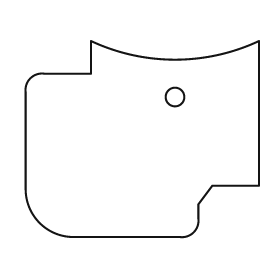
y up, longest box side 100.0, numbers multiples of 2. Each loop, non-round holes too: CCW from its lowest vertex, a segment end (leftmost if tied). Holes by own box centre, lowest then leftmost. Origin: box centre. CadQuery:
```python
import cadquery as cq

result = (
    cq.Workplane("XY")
    .moveTo(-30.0, -42.0)
    .lineTo(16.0, -42.0)
    .threePointArc((22.0, -40.0), (24.0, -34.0))
    .lineTo(24.0, -28.0)
    .lineTo(30.0, -20.0)
    .lineTo(50.0, -20.0)
    .lineTo(50.0, 42.0)
    .threePointArc((14.0, 34.0), (-22.0, 42.0))
    .lineTo(-22.0, 28.0)
    .lineTo(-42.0, 28.0)
    .threePointArc((-48.0, 26.0), (-50.0, 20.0))
    .lineTo(-50.0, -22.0)
    .threePointArc((-44.0, -36.0), (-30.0, -42.0))
    .close()
    .moveTo(14.0, 18.0)
    .circle(4.0)
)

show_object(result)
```